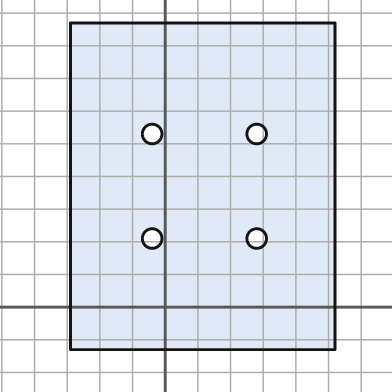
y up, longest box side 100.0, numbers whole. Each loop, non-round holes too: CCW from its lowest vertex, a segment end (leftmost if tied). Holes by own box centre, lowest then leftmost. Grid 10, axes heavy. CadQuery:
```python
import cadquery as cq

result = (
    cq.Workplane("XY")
    .moveTo(-29.0, -13.0)
    .lineTo(52.0, -13.0)
    .lineTo(52.0, 87.0)
    .lineTo(-29.0, 87.0)
    .close()
    .moveTo(-4.0, 21.0)
    .circle(3.0)
    .moveTo(28.0, 21.0)
    .circle(3.0)
    .moveTo(-4.0, 53.0)
    .circle(3.0)
    .moveTo(28.0, 53.0)
    .circle(3.0)
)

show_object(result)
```